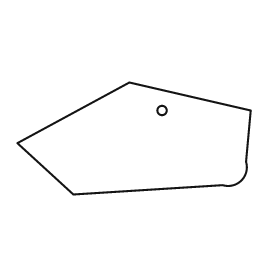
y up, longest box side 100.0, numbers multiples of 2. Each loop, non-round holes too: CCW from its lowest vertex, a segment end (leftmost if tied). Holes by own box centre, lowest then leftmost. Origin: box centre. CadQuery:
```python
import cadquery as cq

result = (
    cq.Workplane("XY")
    .moveTo(-26.0, -24.0)
    .lineTo(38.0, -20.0)
    .threePointArc((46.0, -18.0), (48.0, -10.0))
    .lineTo(50.0, 12.0)
    .lineTo(-2.0, 24.0)
    .lineTo(-50.0, -2.0)
    .close()
    .moveTo(12.0, 12.0)
    .circle(2.0)
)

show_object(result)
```